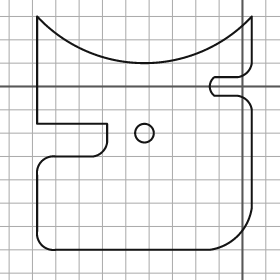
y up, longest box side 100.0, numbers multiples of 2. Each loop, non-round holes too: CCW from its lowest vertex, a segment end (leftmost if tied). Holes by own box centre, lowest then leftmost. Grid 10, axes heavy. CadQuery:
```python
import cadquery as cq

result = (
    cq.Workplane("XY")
    .moveTo(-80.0, -70.0)
    .lineTo(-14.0, -70.0)
    .threePointArc((-2.0, -64.0), (4.0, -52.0))
    .lineTo(4.0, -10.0)
    .threePointArc((2.0, -6.0), (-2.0, -4.0))
    .lineTo(-12.0, -4.0)
    .threePointArc((-14.0, 0.0), (-12.0, 4.0))
    .lineTo(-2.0, 4.0)
    .threePointArc((2.0, 6.0), (4.0, 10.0))
    .lineTo(4.0, 30.0)
    .threePointArc((-42.0, 10.0), (-88.0, 30.0))
    .lineTo(-88.0, -16.0)
    .lineTo(-58.0, -16.0)
    .lineTo(-58.0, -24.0)
    .threePointArc((-60.0, -28.0), (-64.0, -30.0))
    .lineTo(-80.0, -30.0)
    .threePointArc((-86.0, -32.0), (-88.0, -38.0))
    .lineTo(-88.0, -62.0)
    .threePointArc((-86.0, -68.0), (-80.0, -70.0))
    .close()
    .moveTo(-42.0, -20.0)
    .circle(4.0)
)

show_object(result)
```